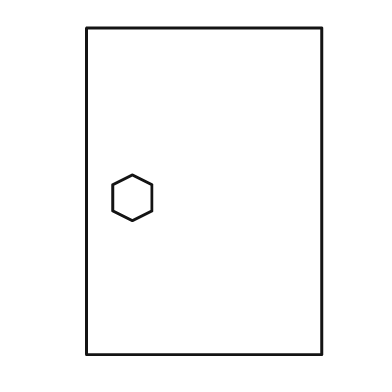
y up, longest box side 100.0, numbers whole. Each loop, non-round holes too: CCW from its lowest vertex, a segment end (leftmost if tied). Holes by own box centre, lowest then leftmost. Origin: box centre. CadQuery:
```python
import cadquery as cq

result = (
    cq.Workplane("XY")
    .moveTo(-36.0, -50.0)
    .lineTo(36.0, -50.0)
    .lineTo(36.0, 50.0)
    .lineTo(-36.0, 50.0)
    .close()
    .moveTo(-22.0, -9.0)
    .lineTo(-16.0, -6.0)
    .lineTo(-16.0, 2.0)
    .lineTo(-22.0, 5.0)
    .lineTo(-28.0, 2.0)
    .lineTo(-28.0, -6.0)
    .close()
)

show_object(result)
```